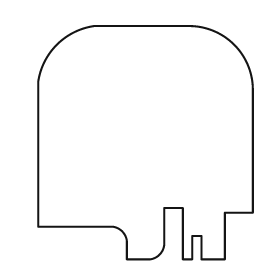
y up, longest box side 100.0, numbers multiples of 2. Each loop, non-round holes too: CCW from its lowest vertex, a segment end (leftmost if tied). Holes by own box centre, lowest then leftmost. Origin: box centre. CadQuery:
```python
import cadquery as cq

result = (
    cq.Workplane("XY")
    .moveTo(-8.0, -50.0)
    .lineTo(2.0, -50.0)
    .threePointArc((6.0, -48.0), (8.0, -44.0))
    .lineTo(8.0, -28.0)
    .lineTo(16.0, -28.0)
    .lineTo(16.0, -50.0)
    .lineTo(20.0, -50.0)
    .lineTo(20.0, -40.0)
    .lineTo(24.0, -40.0)
    .lineTo(24.0, -50.0)
    .lineTo(34.0, -50.0)
    .lineTo(34.0, -30.0)
    .lineTo(46.0, -30.0)
    .lineTo(46.0, 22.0)
    .threePointArc((38.0, 42.0), (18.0, 50.0))
    .lineTo(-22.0, 50.0)
    .threePointArc((-38.0, 42.0), (-46.0, 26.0))
    .lineTo(-46.0, -36.0)
    .lineTo(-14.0, -36.0)
    .threePointArc((-10.0, -38.0), (-8.0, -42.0))
    .close()
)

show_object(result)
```